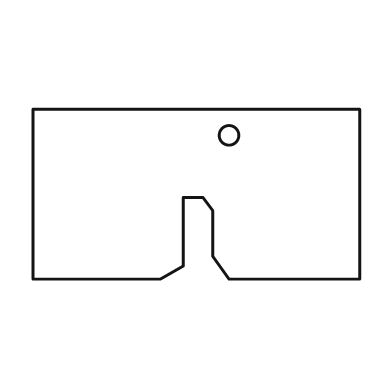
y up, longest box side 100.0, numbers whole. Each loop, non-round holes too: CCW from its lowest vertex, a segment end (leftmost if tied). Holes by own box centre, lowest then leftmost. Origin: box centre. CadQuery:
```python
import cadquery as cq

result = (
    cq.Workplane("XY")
    .moveTo(-50.0, -26.0)
    .lineTo(-11.0, -26.0)
    .lineTo(-4.0, -22.0)
    .lineTo(-4.0, -1.0)
    .lineTo(2.0, -1.0)
    .lineTo(5.0, -5.0)
    .lineTo(5.0, -19.0)
    .lineTo(10.0, -26.0)
    .lineTo(50.0, -26.0)
    .lineTo(50.0, 26.0)
    .lineTo(-50.0, 26.0)
    .close()
    .moveTo(10.0, 18.0)
    .circle(3.0)
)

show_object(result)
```